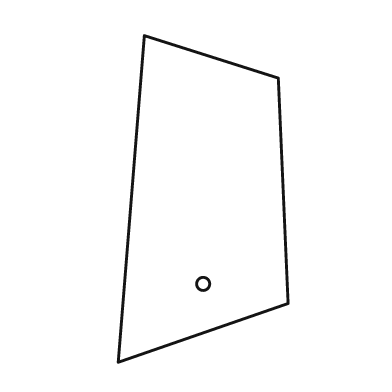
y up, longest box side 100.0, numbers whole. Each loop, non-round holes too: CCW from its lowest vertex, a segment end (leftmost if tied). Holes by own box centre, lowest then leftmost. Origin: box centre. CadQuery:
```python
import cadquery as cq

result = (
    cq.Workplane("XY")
    .moveTo(-26.0, -50.0)
    .lineTo(26.0, -32.0)
    .lineTo(23.0, 37.0)
    .lineTo(-18.0, 50.0)
    .close()
    .moveTo(0.0, -26.0)
    .circle(2.0)
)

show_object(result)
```